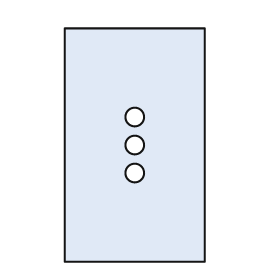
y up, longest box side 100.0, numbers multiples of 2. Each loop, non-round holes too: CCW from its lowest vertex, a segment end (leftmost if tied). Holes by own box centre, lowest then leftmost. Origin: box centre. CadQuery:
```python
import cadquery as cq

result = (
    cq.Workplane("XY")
    .moveTo(-30.0, -50.0)
    .lineTo(30.0, -50.0)
    .lineTo(30.0, 50.0)
    .lineTo(-30.0, 50.0)
    .close()
    .moveTo(0.0, -12.0)
    .circle(4.0)
    .moveTo(0.0, 0.0)
    .circle(4.0)
    .moveTo(0.0, 12.0)
    .circle(4.0)
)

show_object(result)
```